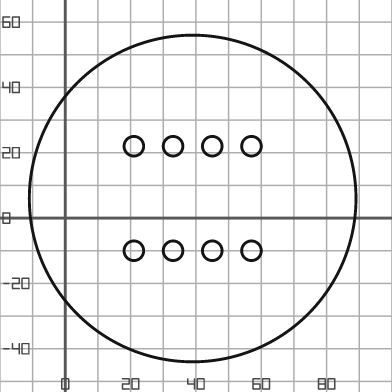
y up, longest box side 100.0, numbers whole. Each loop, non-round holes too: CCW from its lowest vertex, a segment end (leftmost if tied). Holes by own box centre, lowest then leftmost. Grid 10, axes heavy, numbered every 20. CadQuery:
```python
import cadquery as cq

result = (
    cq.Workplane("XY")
    .moveTo(39.0, 6.0)
    .circle(50.0)
    .moveTo(21.0, -10.0)
    .circle(3.0)
    .moveTo(33.0, -10.0)
    .circle(3.0)
    .moveTo(45.0, -10.0)
    .circle(3.0)
    .moveTo(57.0, -10.0)
    .circle(3.0)
    .moveTo(21.0, 22.0)
    .circle(3.0)
    .moveTo(33.0, 22.0)
    .circle(3.0)
    .moveTo(45.0, 22.0)
    .circle(3.0)
    .moveTo(57.0, 22.0)
    .circle(3.0)
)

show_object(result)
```